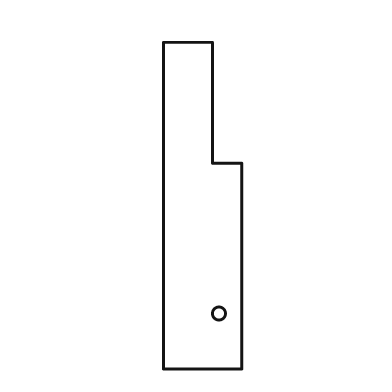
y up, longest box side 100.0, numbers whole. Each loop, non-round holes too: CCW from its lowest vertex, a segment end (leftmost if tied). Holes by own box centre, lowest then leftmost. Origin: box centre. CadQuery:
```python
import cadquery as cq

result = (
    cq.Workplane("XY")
    .moveTo(-12.0, -50.0)
    .lineTo(12.0, -50.0)
    .lineTo(12.0, 13.0)
    .lineTo(3.0, 13.0)
    .lineTo(3.0, 50.0)
    .lineTo(-12.0, 50.0)
    .close()
    .moveTo(5.0, -33.0)
    .circle(2.0)
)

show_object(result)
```